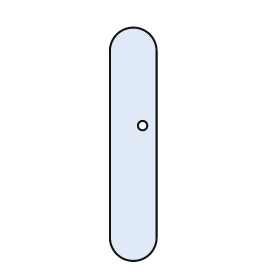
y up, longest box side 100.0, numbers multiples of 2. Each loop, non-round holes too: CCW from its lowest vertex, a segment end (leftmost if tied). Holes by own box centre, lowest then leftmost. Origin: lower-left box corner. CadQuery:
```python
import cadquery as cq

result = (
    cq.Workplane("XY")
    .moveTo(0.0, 10.0)
    .threePointArc((10.0, 0.0), (20.0, 10.0))
    .lineTo(20.0, 90.0)
    .threePointArc((10.0, 100.0), (0.0, 90.0))
    .close()
    .moveTo(14.0, 58.0)
    .circle(2.0)
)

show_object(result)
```